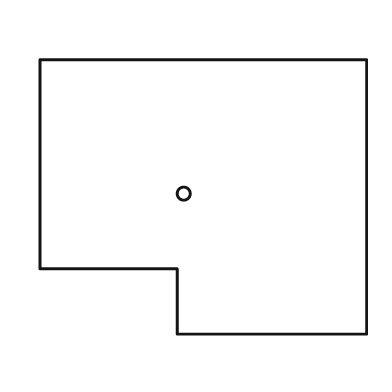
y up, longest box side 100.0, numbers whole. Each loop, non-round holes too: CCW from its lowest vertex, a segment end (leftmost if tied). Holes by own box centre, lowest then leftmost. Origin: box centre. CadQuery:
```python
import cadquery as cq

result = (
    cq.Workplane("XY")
    .moveTo(-8.0, -42.0)
    .lineTo(50.0, -42.0)
    .lineTo(50.0, 42.0)
    .lineTo(-50.0, 42.0)
    .lineTo(-50.0, -22.0)
    .lineTo(-8.0, -22.0)
    .close()
    .moveTo(-6.0, 1.0)
    .circle(2.0)
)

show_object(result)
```